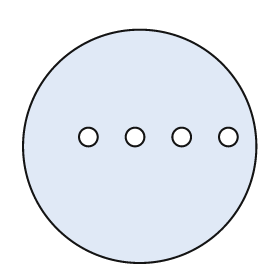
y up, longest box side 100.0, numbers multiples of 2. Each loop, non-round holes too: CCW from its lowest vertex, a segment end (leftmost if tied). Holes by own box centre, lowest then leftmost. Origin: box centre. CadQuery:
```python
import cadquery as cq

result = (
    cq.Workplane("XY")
    .moveTo(0.0, 0.0)
    .circle(50.0)
    .moveTo(-22.0, 4.0)
    .circle(4.0)
    .moveTo(-2.0, 4.0)
    .circle(4.0)
    .moveTo(18.0, 4.0)
    .circle(4.0)
    .moveTo(38.0, 4.0)
    .circle(4.0)
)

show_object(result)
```